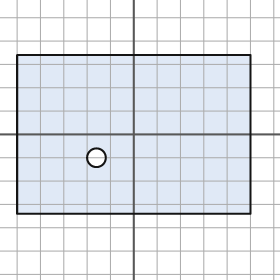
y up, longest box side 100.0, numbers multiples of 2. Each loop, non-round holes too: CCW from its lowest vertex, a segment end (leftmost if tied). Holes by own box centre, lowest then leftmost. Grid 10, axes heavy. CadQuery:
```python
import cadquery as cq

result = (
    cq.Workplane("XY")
    .moveTo(-50.0, -34.0)
    .lineTo(50.0, -34.0)
    .lineTo(50.0, 34.0)
    .lineTo(-50.0, 34.0)
    .close()
    .moveTo(-16.0, -10.0)
    .circle(4.0)
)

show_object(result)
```